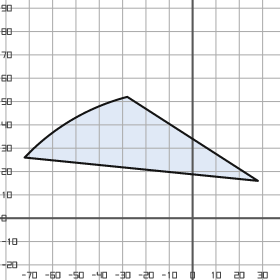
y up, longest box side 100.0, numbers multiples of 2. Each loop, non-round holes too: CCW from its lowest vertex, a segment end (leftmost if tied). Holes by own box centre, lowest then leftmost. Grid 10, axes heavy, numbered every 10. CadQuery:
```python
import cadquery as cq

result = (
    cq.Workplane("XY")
    .moveTo(28.0, 16.0)
    .lineTo(-28.0, 52.0)
    .threePointArc((-52.0, 42.0), (-72.0, 26.0))
    .close()
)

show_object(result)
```